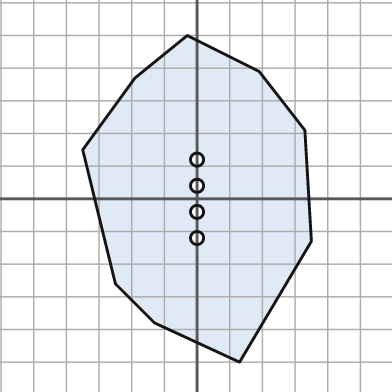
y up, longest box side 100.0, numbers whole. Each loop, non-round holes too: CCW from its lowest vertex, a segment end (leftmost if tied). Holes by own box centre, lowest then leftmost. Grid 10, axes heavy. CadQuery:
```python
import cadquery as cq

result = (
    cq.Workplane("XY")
    .moveTo(13.0, -50.0)
    .lineTo(35.0, -13.0)
    .lineTo(33.0, 21.0)
    .lineTo(19.0, 39.0)
    .lineTo(-3.0, 50.0)
    .lineTo(-19.0, 37.0)
    .lineTo(-35.0, 15.0)
    .lineTo(-25.0, -26.0)
    .lineTo(-13.0, -38.0)
    .close()
    .moveTo(0.0, -12.0)
    .circle(2.0)
    .moveTo(0.0, -4.0)
    .circle(2.0)
    .moveTo(0.0, 4.0)
    .circle(2.0)
    .moveTo(0.0, 12.0)
    .circle(2.0)
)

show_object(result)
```